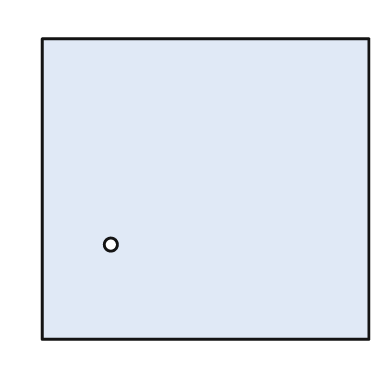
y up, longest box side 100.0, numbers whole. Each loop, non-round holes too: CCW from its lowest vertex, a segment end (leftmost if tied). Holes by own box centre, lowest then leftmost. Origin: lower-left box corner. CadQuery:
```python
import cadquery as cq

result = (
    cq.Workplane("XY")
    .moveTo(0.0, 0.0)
    .lineTo(100.0, 0.0)
    .lineTo(100.0, 92.0)
    .lineTo(0.0, 92.0)
    .close()
    .moveTo(21.0, 29.0)
    .circle(2.0)
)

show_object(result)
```